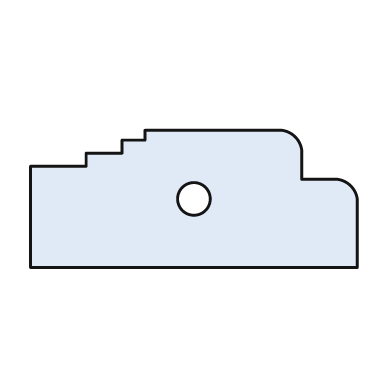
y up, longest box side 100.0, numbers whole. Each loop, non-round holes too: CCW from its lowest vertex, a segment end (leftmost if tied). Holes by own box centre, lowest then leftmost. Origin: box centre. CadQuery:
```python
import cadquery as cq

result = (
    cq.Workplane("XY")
    .moveTo(-50.0, -21.0)
    .lineTo(50.0, -21.0)
    .lineTo(50.0, 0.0)
    .threePointArc((48.0, 4.0), (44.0, 6.0))
    .lineTo(33.0, 6.0)
    .lineTo(33.0, 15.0)
    .threePointArc((31.0, 19.0), (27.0, 21.0))
    .lineTo(-15.0, 21.0)
    .lineTo(-15.0, 18.0)
    .lineTo(-22.0, 18.0)
    .lineTo(-22.0, 14.0)
    .lineTo(-33.0, 14.0)
    .lineTo(-33.0, 10.0)
    .lineTo(-50.0, 10.0)
    .close()
    .moveTo(0.0, 0.0)
    .circle(5.0)
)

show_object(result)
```